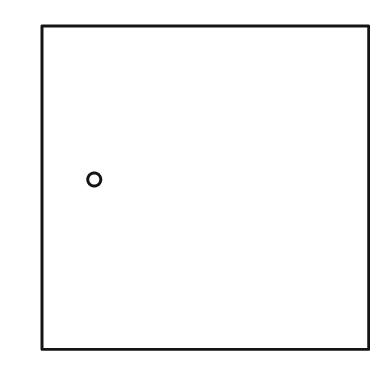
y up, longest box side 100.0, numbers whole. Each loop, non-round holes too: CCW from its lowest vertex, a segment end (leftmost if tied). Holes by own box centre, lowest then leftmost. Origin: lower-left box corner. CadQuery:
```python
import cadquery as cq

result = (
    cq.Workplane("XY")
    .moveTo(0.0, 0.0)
    .lineTo(100.0, 0.0)
    .lineTo(100.0, 99.0)
    .lineTo(0.0, 99.0)
    .close()
    .moveTo(16.0, 52.0)
    .circle(2.0)
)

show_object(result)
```